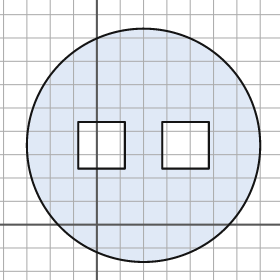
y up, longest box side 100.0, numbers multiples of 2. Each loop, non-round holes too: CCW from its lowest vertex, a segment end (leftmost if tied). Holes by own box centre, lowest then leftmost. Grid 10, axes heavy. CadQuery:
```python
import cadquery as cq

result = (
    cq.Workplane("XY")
    .moveTo(20.0, 34.0)
    .circle(50.0)
    .moveTo(-8.0, 24.0)
    .lineTo(12.0, 24.0)
    .lineTo(12.0, 44.0)
    .lineTo(-8.0, 44.0)
    .close()
    .moveTo(28.0, 24.0)
    .lineTo(48.0, 24.0)
    .lineTo(48.0, 44.0)
    .lineTo(28.0, 44.0)
    .close()
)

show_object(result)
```